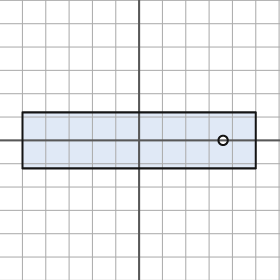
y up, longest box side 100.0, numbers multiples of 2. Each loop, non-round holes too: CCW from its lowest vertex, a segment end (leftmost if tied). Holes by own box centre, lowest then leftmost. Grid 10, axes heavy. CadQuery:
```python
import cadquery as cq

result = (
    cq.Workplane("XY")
    .moveTo(-50.0, -12.0)
    .lineTo(50.0, -12.0)
    .lineTo(50.0, 12.0)
    .lineTo(-50.0, 12.0)
    .close()
    .moveTo(36.0, 0.0)
    .circle(2.0)
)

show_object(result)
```